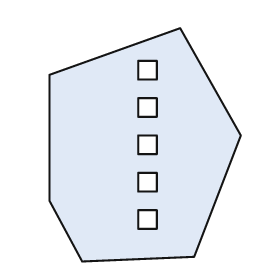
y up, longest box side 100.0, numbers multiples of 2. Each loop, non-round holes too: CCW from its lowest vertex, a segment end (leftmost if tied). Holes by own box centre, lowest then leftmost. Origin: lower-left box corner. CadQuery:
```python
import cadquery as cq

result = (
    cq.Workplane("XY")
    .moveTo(14.0, 0.0)
    .lineTo(62.0, 2.0)
    .lineTo(82.0, 54.0)
    .lineTo(56.0, 100.0)
    .lineTo(0.0, 80.0)
    .lineTo(0.0, 26.0)
    .close()
    .moveTo(38.0, 14.0)
    .lineTo(46.0, 14.0)
    .lineTo(46.0, 22.0)
    .lineTo(38.0, 22.0)
    .close()
    .moveTo(38.0, 30.0)
    .lineTo(46.0, 30.0)
    .lineTo(46.0, 38.0)
    .lineTo(38.0, 38.0)
    .close()
    .moveTo(38.0, 46.0)
    .lineTo(46.0, 46.0)
    .lineTo(46.0, 54.0)
    .lineTo(38.0, 54.0)
    .close()
    .moveTo(38.0, 62.0)
    .lineTo(46.0, 62.0)
    .lineTo(46.0, 70.0)
    .lineTo(38.0, 70.0)
    .close()
    .moveTo(38.0, 78.0)
    .lineTo(46.0, 78.0)
    .lineTo(46.0, 86.0)
    .lineTo(38.0, 86.0)
    .close()
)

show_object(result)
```